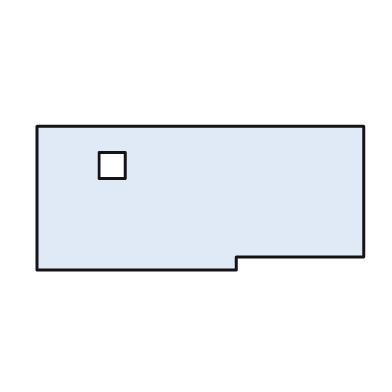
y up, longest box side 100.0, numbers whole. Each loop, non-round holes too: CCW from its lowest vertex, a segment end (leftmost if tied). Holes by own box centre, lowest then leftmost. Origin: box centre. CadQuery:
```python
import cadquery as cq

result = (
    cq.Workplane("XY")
    .moveTo(-50.0, -22.0)
    .lineTo(11.0, -22.0)
    .lineTo(11.0, -18.0)
    .lineTo(50.0, -18.0)
    .lineTo(50.0, 22.0)
    .lineTo(-50.0, 22.0)
    .close()
    .moveTo(-31.0, 6.0)
    .lineTo(-23.0, 6.0)
    .lineTo(-23.0, 14.0)
    .lineTo(-31.0, 14.0)
    .close()
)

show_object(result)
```